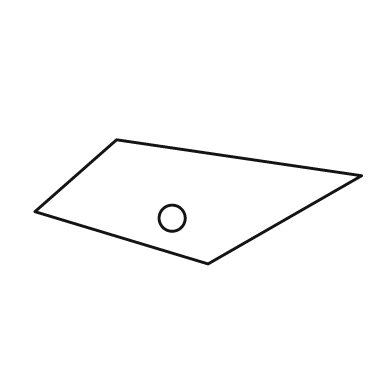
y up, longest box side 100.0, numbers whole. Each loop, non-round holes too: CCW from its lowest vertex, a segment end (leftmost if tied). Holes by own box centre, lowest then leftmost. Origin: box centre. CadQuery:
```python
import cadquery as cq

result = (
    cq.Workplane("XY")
    .moveTo(3.0, -19.0)
    .lineTo(50.0, 8.0)
    .lineTo(-25.0, 19.0)
    .lineTo(-50.0, -3.0)
    .close()
    .moveTo(-8.0, -5.0)
    .circle(4.0)
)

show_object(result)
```